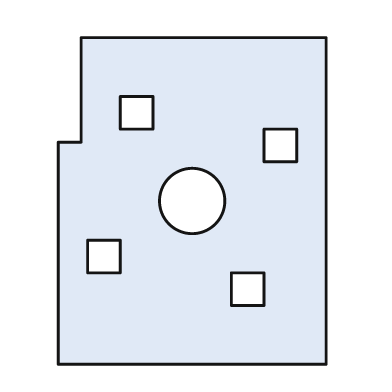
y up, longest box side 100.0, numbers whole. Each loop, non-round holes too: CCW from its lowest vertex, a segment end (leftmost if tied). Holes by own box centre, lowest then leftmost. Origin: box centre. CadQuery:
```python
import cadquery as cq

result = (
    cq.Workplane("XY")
    .moveTo(-41.0, -50.0)
    .lineTo(41.0, -50.0)
    .lineTo(41.0, 50.0)
    .lineTo(-34.0, 50.0)
    .lineTo(-34.0, 18.0)
    .lineTo(-41.0, 18.0)
    .close()
    .moveTo(12.0, -32.0)
    .lineTo(22.0, -32.0)
    .lineTo(22.0, -22.0)
    .lineTo(12.0, -22.0)
    .close()
    .moveTo(-32.0, -22.0)
    .lineTo(-22.0, -22.0)
    .lineTo(-22.0, -12.0)
    .lineTo(-32.0, -12.0)
    .close()
    .moveTo(0.0, 0.0)
    .circle(10.0)
    .moveTo(22.0, 12.0)
    .lineTo(32.0, 12.0)
    .lineTo(32.0, 22.0)
    .lineTo(22.0, 22.0)
    .close()
    .moveTo(-22.0, 22.0)
    .lineTo(-12.0, 22.0)
    .lineTo(-12.0, 32.0)
    .lineTo(-22.0, 32.0)
    .close()
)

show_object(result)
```